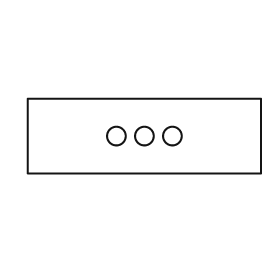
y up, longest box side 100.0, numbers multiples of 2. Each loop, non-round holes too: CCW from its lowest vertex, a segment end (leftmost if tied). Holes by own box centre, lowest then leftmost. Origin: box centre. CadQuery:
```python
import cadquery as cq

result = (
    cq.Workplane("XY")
    .moveTo(-50.0, -16.0)
    .lineTo(50.0, -16.0)
    .lineTo(50.0, 16.0)
    .lineTo(-50.0, 16.0)
    .close()
    .moveTo(-12.0, 0.0)
    .circle(4.0)
    .moveTo(0.0, 0.0)
    .circle(4.0)
    .moveTo(12.0, 0.0)
    .circle(4.0)
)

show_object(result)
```